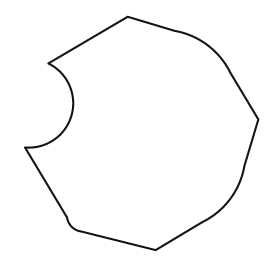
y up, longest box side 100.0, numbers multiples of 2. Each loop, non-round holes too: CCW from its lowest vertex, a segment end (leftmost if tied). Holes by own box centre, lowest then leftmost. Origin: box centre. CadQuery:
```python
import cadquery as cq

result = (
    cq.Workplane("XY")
    .moveTo(6.0, -50.0)
    .lineTo(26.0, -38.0)
    .threePointArc((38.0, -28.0), (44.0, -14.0))
    .lineTo(50.0, 6.0)
    .lineTo(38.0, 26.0)
    .threePointArc((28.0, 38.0), (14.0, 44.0))
    .lineTo(-6.0, 50.0)
    .lineTo(-40.0, 30.0)
    .threePointArc((-30.0, 8.0), (-50.0, -6.0))
    .lineTo(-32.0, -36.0)
    .threePointArc((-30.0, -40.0), (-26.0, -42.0))
    .close()
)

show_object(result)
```